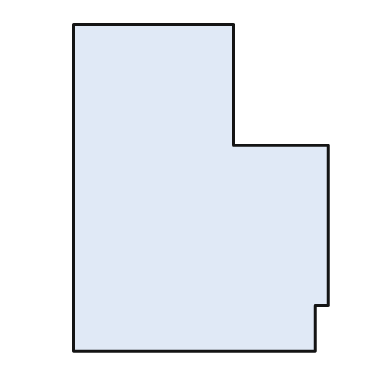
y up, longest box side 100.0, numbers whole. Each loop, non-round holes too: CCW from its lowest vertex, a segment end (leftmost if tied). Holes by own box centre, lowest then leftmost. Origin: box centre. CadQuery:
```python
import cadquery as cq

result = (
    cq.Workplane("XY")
    .moveTo(-39.0, -50.0)
    .lineTo(35.0, -50.0)
    .lineTo(35.0, -36.0)
    .lineTo(39.0, -36.0)
    .lineTo(39.0, 13.0)
    .lineTo(10.0, 13.0)
    .lineTo(10.0, 50.0)
    .lineTo(-39.0, 50.0)
    .close()
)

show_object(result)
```